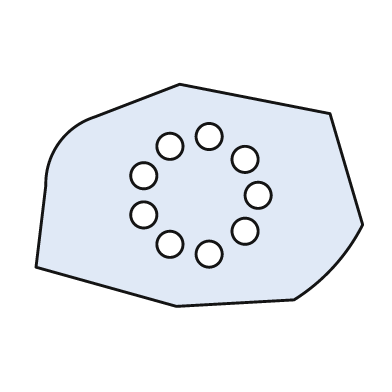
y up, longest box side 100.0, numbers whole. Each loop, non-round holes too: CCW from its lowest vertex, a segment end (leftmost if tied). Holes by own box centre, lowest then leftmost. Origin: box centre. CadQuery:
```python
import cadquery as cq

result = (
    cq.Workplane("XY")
    .moveTo(-7.0, -34.0)
    .lineTo(29.0, -32.0)
    .threePointArc((41.0, -22.0), (50.0, -9.0))
    .lineTo(40.0, 25.0)
    .lineTo(-6.0, 34.0)
    .lineTo(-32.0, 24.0)
    .threePointArc((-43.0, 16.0), (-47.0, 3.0))
    .lineTo(-50.0, -22.0)
    .close()
    .moveTo(3.0, -18.0)
    .circle(4.0)
    .moveTo(-9.0, -15.0)
    .circle(4.0)
    .moveTo(14.0, -11.0)
    .circle(4.0)
    .moveTo(-17.0, -6.0)
    .circle(4.0)
    .moveTo(18.0, 0.0)
    .circle(4.0)
    .moveTo(-17.0, 6.0)
    .circle(4.0)
    .moveTo(14.0, 11.0)
    .circle(4.0)
    .moveTo(-9.0, 15.0)
    .circle(4.0)
    .moveTo(3.0, 18.0)
    .circle(4.0)
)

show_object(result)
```